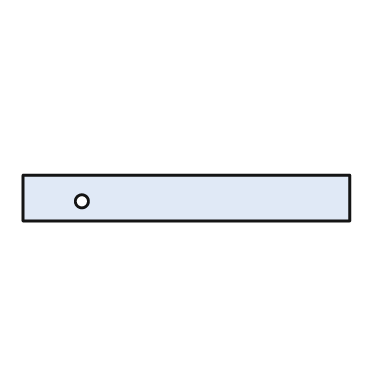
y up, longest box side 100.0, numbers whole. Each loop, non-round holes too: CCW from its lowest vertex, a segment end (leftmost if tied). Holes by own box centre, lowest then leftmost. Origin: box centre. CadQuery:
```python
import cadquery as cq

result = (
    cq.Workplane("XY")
    .moveTo(-50.0, -7.0)
    .lineTo(50.0, -7.0)
    .lineTo(50.0, 7.0)
    .lineTo(-50.0, 7.0)
    .close()
    .moveTo(-32.0, -1.0)
    .circle(2.0)
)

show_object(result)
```